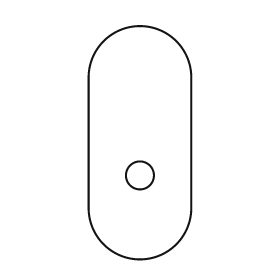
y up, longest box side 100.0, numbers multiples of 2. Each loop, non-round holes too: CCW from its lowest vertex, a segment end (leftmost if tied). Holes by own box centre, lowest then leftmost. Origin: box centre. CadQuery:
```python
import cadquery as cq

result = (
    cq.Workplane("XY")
    .moveTo(-22.0, -28.0)
    .threePointArc((0.0, -50.0), (22.0, -28.0))
    .lineTo(22.0, 28.0)
    .threePointArc((0.0, 50.0), (-22.0, 28.0))
    .close()
    .moveTo(0.0, -14.0)
    .circle(6.0)
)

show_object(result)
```